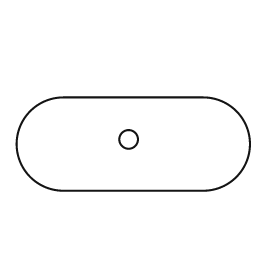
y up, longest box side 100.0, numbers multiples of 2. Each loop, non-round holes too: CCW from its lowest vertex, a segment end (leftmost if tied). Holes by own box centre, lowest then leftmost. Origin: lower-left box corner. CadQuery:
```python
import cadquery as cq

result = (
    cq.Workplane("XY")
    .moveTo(20.0, 0.0)
    .lineTo(80.0, 0.0)
    .threePointArc((100.0, 20.0), (80.0, 40.0))
    .lineTo(20.0, 40.0)
    .threePointArc((0.0, 20.0), (20.0, 0.0))
    .close()
    .moveTo(48.0, 22.0)
    .circle(4.0)
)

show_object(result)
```